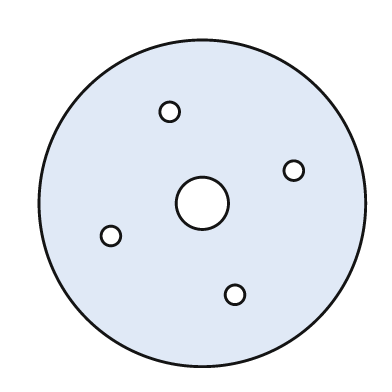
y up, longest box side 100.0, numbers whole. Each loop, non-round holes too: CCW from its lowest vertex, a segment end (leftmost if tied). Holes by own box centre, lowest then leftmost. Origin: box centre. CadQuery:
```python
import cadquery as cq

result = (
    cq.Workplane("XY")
    .moveTo(0.0, 0.0)
    .circle(50.0)
    .moveTo(10.0, -28.0)
    .circle(3.0)
    .moveTo(-28.0, -10.0)
    .circle(3.0)
    .moveTo(0.0, 0.0)
    .circle(8.0)
    .moveTo(28.0, 10.0)
    .circle(3.0)
    .moveTo(-10.0, 28.0)
    .circle(3.0)
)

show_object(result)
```